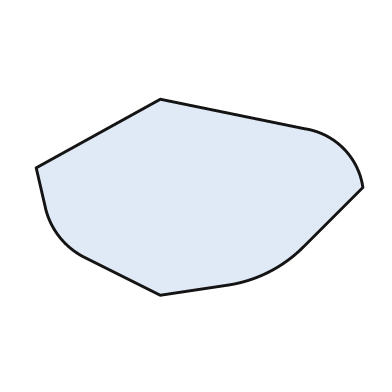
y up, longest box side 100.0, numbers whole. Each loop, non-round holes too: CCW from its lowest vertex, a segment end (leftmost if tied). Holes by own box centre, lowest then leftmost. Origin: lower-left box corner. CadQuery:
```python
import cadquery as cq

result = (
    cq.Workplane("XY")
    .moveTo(38.0, 0.0)
    .lineTo(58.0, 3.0)
    .threePointArc((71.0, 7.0), (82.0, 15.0))
    .lineTo(100.0, 33.0)
    .threePointArc((94.0, 45.0), (82.0, 51.0))
    .lineTo(38.0, 60.0)
    .lineTo(0.0, 39.0)
    .lineTo(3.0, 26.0)
    .threePointArc((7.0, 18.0), (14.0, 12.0))
    .close()
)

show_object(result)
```